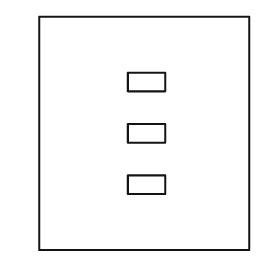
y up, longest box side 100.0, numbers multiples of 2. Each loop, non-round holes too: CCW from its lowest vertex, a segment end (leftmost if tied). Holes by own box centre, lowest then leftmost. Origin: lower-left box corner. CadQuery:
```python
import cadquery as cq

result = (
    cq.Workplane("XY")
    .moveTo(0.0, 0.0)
    .lineTo(90.0, 0.0)
    .lineTo(90.0, 100.0)
    .lineTo(0.0, 100.0)
    .close()
    .moveTo(38.0, 24.0)
    .lineTo(54.0, 24.0)
    .lineTo(54.0, 32.0)
    .lineTo(38.0, 32.0)
    .close()
    .moveTo(38.0, 46.0)
    .lineTo(54.0, 46.0)
    .lineTo(54.0, 54.0)
    .lineTo(38.0, 54.0)
    .close()
    .moveTo(38.0, 68.0)
    .lineTo(54.0, 68.0)
    .lineTo(54.0, 76.0)
    .lineTo(38.0, 76.0)
    .close()
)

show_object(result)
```